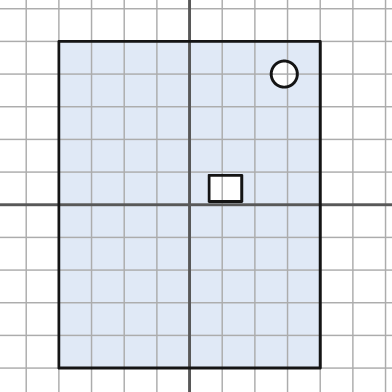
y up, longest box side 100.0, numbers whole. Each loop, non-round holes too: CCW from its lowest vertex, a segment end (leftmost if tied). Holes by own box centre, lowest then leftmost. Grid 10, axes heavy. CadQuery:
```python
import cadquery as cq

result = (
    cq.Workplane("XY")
    .moveTo(-40.0, -50.0)
    .lineTo(40.0, -50.0)
    .lineTo(40.0, 50.0)
    .lineTo(-40.0, 50.0)
    .close()
    .moveTo(6.0, 1.0)
    .lineTo(16.0, 1.0)
    .lineTo(16.0, 9.0)
    .lineTo(6.0, 9.0)
    .close()
    .moveTo(29.0, 40.0)
    .circle(4.0)
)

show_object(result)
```